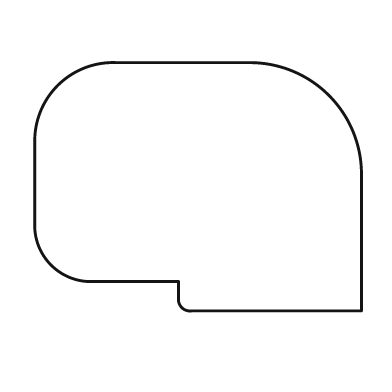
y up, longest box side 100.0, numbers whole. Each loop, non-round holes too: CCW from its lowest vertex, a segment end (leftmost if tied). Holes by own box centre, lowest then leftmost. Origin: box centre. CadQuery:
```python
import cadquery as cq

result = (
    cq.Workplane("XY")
    .moveTo(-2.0, -38.0)
    .lineTo(50.0, -38.0)
    .lineTo(50.0, 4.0)
    .threePointArc((40.0, 28.0), (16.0, 38.0))
    .lineTo(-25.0, 38.0)
    .threePointArc((-43.0, 31.0), (-50.0, 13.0))
    .lineTo(-50.0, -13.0)
    .threePointArc((-45.0, -24.0), (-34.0, -29.0))
    .lineTo(-6.0, -29.0)
    .lineTo(-6.0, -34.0)
    .threePointArc((-5.0, -37.0), (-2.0, -38.0))
    .close()
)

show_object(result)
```